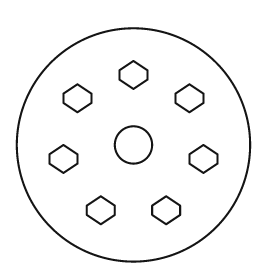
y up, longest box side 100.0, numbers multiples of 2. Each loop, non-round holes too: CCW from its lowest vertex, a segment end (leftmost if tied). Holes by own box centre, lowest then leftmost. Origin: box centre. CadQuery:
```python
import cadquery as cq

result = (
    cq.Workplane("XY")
    .moveTo(0.0, 0.0)
    .circle(50.0)
    .moveTo(-14.0, -34.0)
    .lineTo(-8.0, -30.0)
    .lineTo(-8.0, -26.0)
    .lineTo(-14.0, -22.0)
    .lineTo(-20.0, -26.0)
    .lineTo(-20.0, -30.0)
    .close()
    .moveTo(14.0, -34.0)
    .lineTo(20.0, -30.0)
    .lineTo(20.0, -26.0)
    .lineTo(14.0, -22.0)
    .lineTo(8.0, -26.0)
    .lineTo(8.0, -30.0)
    .close()
    .moveTo(-30.0, -12.0)
    .lineTo(-24.0, -8.0)
    .lineTo(-24.0, -4.0)
    .lineTo(-30.0, 0.0)
    .lineTo(-36.0, -4.0)
    .lineTo(-36.0, -8.0)
    .close()
    .moveTo(30.0, -12.0)
    .lineTo(36.0, -8.0)
    .lineTo(36.0, -4.0)
    .lineTo(30.0, 0.0)
    .lineTo(24.0, -4.0)
    .lineTo(24.0, -8.0)
    .close()
    .moveTo(0.0, 0.0)
    .circle(8.0)
    .moveTo(-24.0, 14.0)
    .lineTo(-18.0, 18.0)
    .lineTo(-18.0, 22.0)
    .lineTo(-24.0, 26.0)
    .lineTo(-30.0, 22.0)
    .lineTo(-30.0, 18.0)
    .close()
    .moveTo(24.0, 14.0)
    .lineTo(30.0, 18.0)
    .lineTo(30.0, 22.0)
    .lineTo(24.0, 26.0)
    .lineTo(18.0, 22.0)
    .lineTo(18.0, 18.0)
    .close()
    .moveTo(0.0, 24.0)
    .lineTo(6.0, 28.0)
    .lineTo(6.0, 32.0)
    .lineTo(0.0, 36.0)
    .lineTo(-6.0, 32.0)
    .lineTo(-6.0, 28.0)
    .close()
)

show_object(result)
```